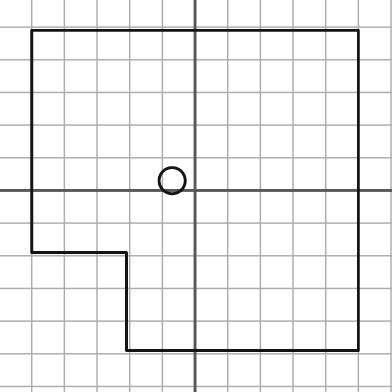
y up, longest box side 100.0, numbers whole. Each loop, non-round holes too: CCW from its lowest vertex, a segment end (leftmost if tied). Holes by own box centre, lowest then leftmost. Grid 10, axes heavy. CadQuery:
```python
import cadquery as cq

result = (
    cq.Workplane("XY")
    .moveTo(-21.0, -49.0)
    .lineTo(50.0, -49.0)
    .lineTo(50.0, 49.0)
    .lineTo(-50.0, 49.0)
    .lineTo(-50.0, -19.0)
    .lineTo(-21.0, -19.0)
    .close()
    .moveTo(-7.0, 3.0)
    .circle(4.0)
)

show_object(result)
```